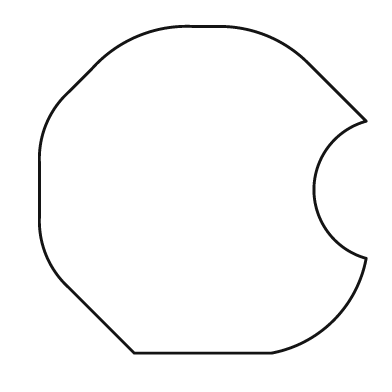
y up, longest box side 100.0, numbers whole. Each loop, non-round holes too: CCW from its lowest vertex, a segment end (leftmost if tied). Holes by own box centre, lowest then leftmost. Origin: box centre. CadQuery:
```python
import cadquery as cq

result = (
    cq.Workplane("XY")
    .moveTo(-21.0, -50.0)
    .lineTo(21.0, -50.0)
    .threePointArc((40.0, -40.0), (50.0, -21.0))
    .threePointArc((34.0, 0.0), (50.0, 21.0))
    .lineTo(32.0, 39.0)
    .threePointArc((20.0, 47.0), (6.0, 50.0))
    .lineTo(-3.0, 50.0)
    .threePointArc((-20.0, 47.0), (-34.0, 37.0))
    .lineTo(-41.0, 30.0)
    .threePointArc((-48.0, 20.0), (-50.0, 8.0))
    .lineTo(-50.0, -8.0)
    .threePointArc((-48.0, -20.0), (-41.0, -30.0))
    .close()
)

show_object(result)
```